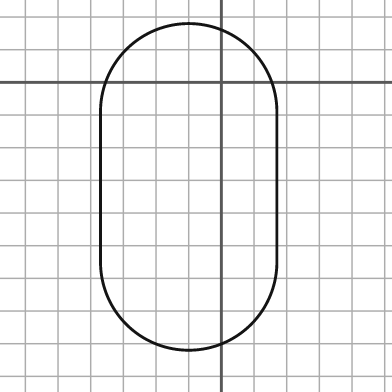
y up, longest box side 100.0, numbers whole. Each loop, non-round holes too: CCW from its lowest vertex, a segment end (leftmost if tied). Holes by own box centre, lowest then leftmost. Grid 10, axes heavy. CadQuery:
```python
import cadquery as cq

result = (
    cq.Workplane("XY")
    .moveTo(-37.0, -55.0)
    .threePointArc((-10.0, -82.0), (17.0, -55.0))
    .lineTo(17.0, -9.0)
    .threePointArc((-10.0, 18.0), (-37.0, -9.0))
    .close()
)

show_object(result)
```